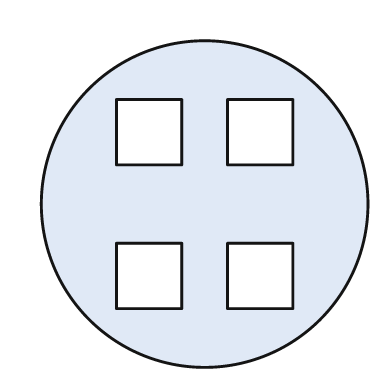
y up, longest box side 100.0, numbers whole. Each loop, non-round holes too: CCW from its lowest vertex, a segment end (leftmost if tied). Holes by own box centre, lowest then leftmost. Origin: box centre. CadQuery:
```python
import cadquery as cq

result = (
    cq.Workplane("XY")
    .moveTo(0.0, 0.0)
    .circle(50.0)
    .moveTo(-27.0, -32.0)
    .lineTo(-7.0, -32.0)
    .lineTo(-7.0, -12.0)
    .lineTo(-27.0, -12.0)
    .close()
    .moveTo(7.0, -32.0)
    .lineTo(27.0, -32.0)
    .lineTo(27.0, -12.0)
    .lineTo(7.0, -12.0)
    .close()
    .moveTo(-27.0, 12.0)
    .lineTo(-7.0, 12.0)
    .lineTo(-7.0, 32.0)
    .lineTo(-27.0, 32.0)
    .close()
    .moveTo(7.0, 12.0)
    .lineTo(27.0, 12.0)
    .lineTo(27.0, 32.0)
    .lineTo(7.0, 32.0)
    .close()
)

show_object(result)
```